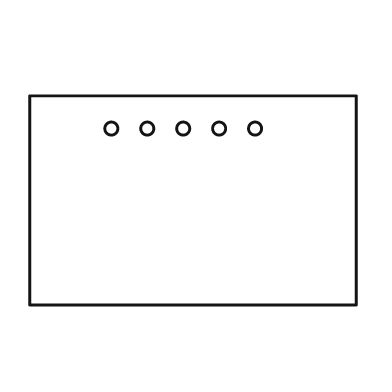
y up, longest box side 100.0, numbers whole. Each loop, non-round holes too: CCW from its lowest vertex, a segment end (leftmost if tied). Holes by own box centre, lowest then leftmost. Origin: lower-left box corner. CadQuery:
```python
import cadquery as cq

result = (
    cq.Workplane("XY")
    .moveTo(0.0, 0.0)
    .lineTo(100.0, 0.0)
    .lineTo(100.0, 64.0)
    .lineTo(0.0, 64.0)
    .close()
    .moveTo(25.0, 54.0)
    .circle(2.0)
    .moveTo(36.0, 54.0)
    .circle(2.0)
    .moveTo(47.0, 54.0)
    .circle(2.0)
    .moveTo(58.0, 54.0)
    .circle(2.0)
    .moveTo(69.0, 54.0)
    .circle(2.0)
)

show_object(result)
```